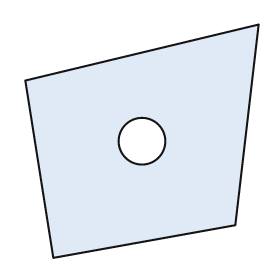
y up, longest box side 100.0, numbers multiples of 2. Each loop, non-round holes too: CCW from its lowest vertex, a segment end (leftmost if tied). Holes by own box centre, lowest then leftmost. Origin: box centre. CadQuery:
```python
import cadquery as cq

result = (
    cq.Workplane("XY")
    .moveTo(-38.0, -50.0)
    .lineTo(40.0, -36.0)
    .lineTo(50.0, 50.0)
    .lineTo(-50.0, 26.0)
    .close()
    .moveTo(0.0, 0.0)
    .circle(10.0)
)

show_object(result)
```